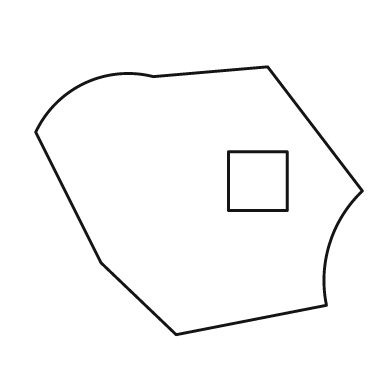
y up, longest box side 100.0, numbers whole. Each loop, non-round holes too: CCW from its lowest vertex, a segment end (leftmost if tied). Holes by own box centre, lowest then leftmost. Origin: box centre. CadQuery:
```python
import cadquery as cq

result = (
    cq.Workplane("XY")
    .moveTo(-7.0, -41.0)
    .lineTo(39.0, -32.0)
    .threePointArc((40.0, -13.0), (50.0, 3.0))
    .lineTo(21.0, 41.0)
    .lineTo(-14.0, 38.0)
    .threePointArc((-35.0, 36.0), (-50.0, 21.0))
    .lineTo(-30.0, -19.0)
    .close()
    .moveTo(9.0, -3.0)
    .lineTo(27.0, -3.0)
    .lineTo(27.0, 15.0)
    .lineTo(9.0, 15.0)
    .close()
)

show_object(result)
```